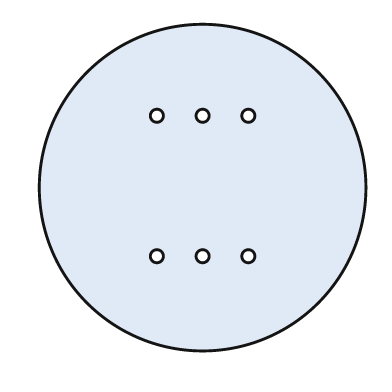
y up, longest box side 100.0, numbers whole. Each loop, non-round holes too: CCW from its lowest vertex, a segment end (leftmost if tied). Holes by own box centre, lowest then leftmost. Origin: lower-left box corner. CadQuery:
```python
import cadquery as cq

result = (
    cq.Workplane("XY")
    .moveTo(50.0, 50.0)
    .circle(50.0)
    .moveTo(36.0, 29.0)
    .circle(2.0)
    .moveTo(50.0, 29.0)
    .circle(2.0)
    .moveTo(64.0, 29.0)
    .circle(2.0)
    .moveTo(36.0, 72.0)
    .circle(2.0)
    .moveTo(50.0, 72.0)
    .circle(2.0)
    .moveTo(64.0, 72.0)
    .circle(2.0)
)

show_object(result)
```